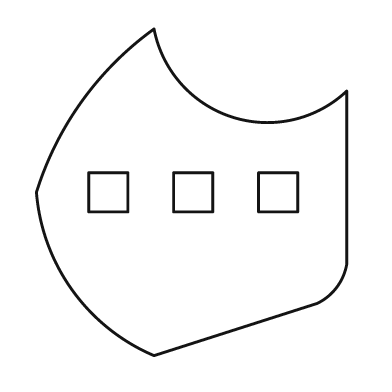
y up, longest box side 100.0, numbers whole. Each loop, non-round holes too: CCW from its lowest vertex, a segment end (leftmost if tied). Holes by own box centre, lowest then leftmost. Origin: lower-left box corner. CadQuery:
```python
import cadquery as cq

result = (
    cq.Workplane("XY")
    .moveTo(36.0, 0.0)
    .lineTo(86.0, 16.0)
    .threePointArc((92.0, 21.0), (95.0, 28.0))
    .lineTo(95.0, 81.0)
    .threePointArc((60.0, 73.0), (36.0, 100.0))
    .threePointArc((14.0, 78.0), (0.0, 50.0))
    .threePointArc((11.0, 20.0), (36.0, 0.0))
    .close()
    .moveTo(16.0, 44.0)
    .lineTo(28.0, 44.0)
    .lineTo(28.0, 56.0)
    .lineTo(16.0, 56.0)
    .close()
    .moveTo(42.0, 44.0)
    .lineTo(54.0, 44.0)
    .lineTo(54.0, 56.0)
    .lineTo(42.0, 56.0)
    .close()
    .moveTo(68.0, 44.0)
    .lineTo(80.0, 44.0)
    .lineTo(80.0, 56.0)
    .lineTo(68.0, 56.0)
    .close()
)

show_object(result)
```